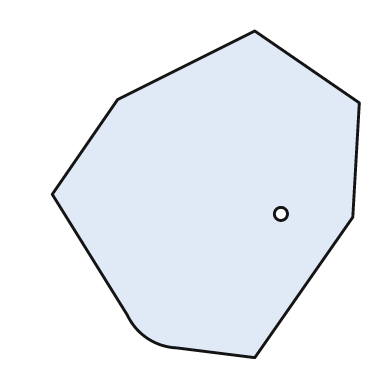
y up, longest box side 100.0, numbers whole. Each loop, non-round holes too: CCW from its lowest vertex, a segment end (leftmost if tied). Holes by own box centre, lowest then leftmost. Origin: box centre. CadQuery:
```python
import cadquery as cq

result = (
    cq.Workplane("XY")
    .moveTo(15.0, -50.0)
    .lineTo(45.0, -7.0)
    .lineTo(47.0, 28.0)
    .lineTo(15.0, 50.0)
    .lineTo(-27.0, 29.0)
    .lineTo(-47.0, 0.0)
    .lineTo(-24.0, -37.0)
    .threePointArc((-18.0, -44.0), (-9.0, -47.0))
    .close()
    .moveTo(23.0, -6.0)
    .circle(2.0)
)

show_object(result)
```